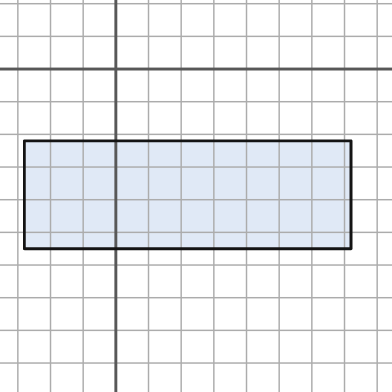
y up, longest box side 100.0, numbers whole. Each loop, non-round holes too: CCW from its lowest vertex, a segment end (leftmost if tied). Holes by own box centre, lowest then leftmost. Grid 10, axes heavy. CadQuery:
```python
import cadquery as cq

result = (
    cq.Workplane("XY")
    .moveTo(-28.0, -55.0)
    .lineTo(72.0, -55.0)
    .lineTo(72.0, -22.0)
    .lineTo(-28.0, -22.0)
    .close()
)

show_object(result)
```